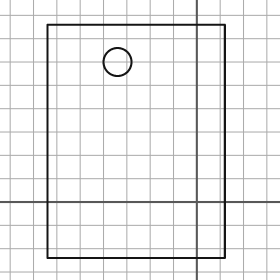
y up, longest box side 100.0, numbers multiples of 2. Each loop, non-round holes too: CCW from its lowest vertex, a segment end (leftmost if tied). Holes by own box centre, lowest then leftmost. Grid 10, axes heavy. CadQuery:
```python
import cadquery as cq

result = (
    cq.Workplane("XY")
    .moveTo(-64.0, -24.0)
    .lineTo(12.0, -24.0)
    .lineTo(12.0, 76.0)
    .lineTo(-64.0, 76.0)
    .close()
    .moveTo(-34.0, 60.0)
    .circle(6.0)
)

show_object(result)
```